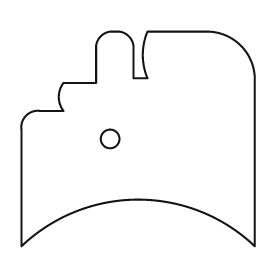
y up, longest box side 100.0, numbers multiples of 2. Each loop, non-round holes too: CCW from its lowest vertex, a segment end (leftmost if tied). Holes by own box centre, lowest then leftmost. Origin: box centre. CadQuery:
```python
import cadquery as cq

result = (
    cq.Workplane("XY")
    .moveTo(-50.0, -46.0)
    .threePointArc((0.0, -26.0), (50.0, -46.0))
    .lineTo(50.0, 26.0)
    .threePointArc((44.0, 40.0), (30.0, 46.0))
    .lineTo(4.0, 46.0)
    .threePointArc((2.0, 36.0), (4.0, 26.0))
    .lineTo(-2.0, 26.0)
    .lineTo(-2.0, 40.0)
    .threePointArc((-4.0, 44.0), (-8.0, 46.0))
    .lineTo(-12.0, 46.0)
    .threePointArc((-16.0, 44.0), (-18.0, 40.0))
    .lineTo(-18.0, 24.0)
    .lineTo(-32.0, 24.0)
    .threePointArc((-34.0, 18.0), (-32.0, 12.0))
    .lineTo(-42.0, 12.0)
    .threePointArc((-48.0, 10.0), (-50.0, 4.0))
    .close()
    .moveTo(-12.0, 0.0)
    .circle(4.0)
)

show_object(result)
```